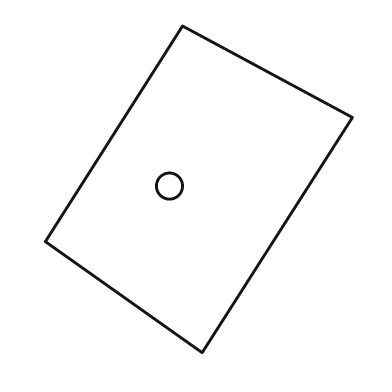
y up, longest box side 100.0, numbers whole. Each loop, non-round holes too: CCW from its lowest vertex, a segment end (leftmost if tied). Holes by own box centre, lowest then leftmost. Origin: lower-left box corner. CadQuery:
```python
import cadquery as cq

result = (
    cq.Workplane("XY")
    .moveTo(48.0, 0.0)
    .lineTo(94.0, 72.0)
    .lineTo(42.0, 100.0)
    .lineTo(0.0, 34.0)
    .close()
    .moveTo(38.0, 51.0)
    .circle(4.0)
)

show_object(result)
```